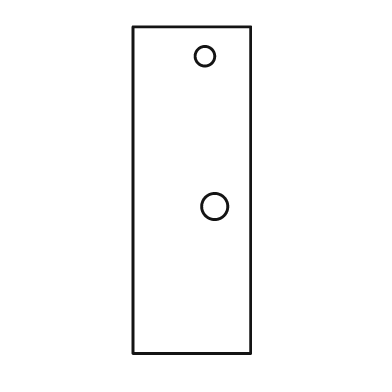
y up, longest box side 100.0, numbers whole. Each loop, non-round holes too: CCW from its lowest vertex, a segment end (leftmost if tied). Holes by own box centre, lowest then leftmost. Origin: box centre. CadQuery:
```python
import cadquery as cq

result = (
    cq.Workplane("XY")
    .moveTo(-18.0, -50.0)
    .lineTo(18.0, -50.0)
    .lineTo(18.0, 50.0)
    .lineTo(-18.0, 50.0)
    .close()
    .moveTo(7.0, -5.0)
    .circle(4.0)
    .moveTo(4.0, 41.0)
    .circle(3.0)
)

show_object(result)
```